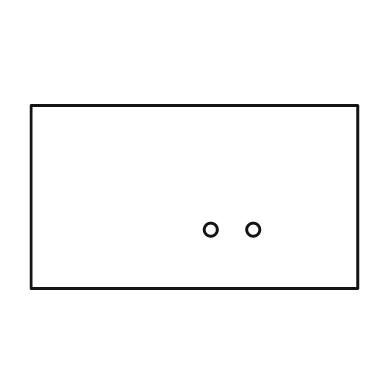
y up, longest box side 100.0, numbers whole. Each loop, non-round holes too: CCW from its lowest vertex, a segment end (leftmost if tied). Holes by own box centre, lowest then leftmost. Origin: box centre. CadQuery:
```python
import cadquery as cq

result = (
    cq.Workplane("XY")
    .moveTo(-50.0, -28.0)
    .lineTo(50.0, -28.0)
    .lineTo(50.0, 28.0)
    .lineTo(-50.0, 28.0)
    .close()
    .moveTo(5.0, -10.0)
    .circle(2.0)
    .moveTo(18.0, -10.0)
    .circle(2.0)
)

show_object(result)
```